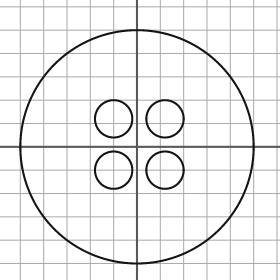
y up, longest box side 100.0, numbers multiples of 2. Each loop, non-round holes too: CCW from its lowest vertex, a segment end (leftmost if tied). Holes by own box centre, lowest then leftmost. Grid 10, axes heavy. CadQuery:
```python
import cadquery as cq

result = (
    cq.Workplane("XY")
    .moveTo(0.0, 0.0)
    .circle(50.0)
    .moveTo(-10.0, -10.0)
    .circle(8.0)
    .moveTo(12.0, -10.0)
    .circle(8.0)
    .moveTo(-10.0, 12.0)
    .circle(8.0)
    .moveTo(12.0, 12.0)
    .circle(8.0)
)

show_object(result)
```